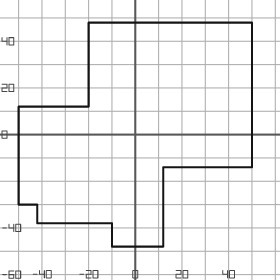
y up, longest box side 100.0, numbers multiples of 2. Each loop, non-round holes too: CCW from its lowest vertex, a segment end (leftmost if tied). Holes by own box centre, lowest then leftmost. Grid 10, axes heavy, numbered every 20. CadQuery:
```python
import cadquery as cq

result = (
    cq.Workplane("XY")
    .moveTo(-10.0, -48.0)
    .lineTo(12.0, -48.0)
    .lineTo(12.0, -14.0)
    .lineTo(50.0, -14.0)
    .lineTo(50.0, 48.0)
    .lineTo(-20.0, 48.0)
    .lineTo(-20.0, 12.0)
    .lineTo(-50.0, 12.0)
    .lineTo(-50.0, -30.0)
    .lineTo(-42.0, -30.0)
    .lineTo(-42.0, -38.0)
    .lineTo(-10.0, -38.0)
    .close()
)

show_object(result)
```